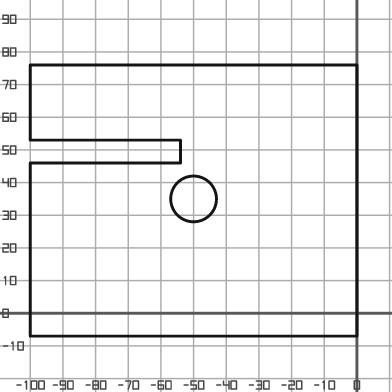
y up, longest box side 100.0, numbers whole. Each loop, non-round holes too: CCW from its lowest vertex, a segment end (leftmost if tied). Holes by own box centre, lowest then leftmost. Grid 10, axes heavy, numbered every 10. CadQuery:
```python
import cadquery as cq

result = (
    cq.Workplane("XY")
    .moveTo(-100.0, -7.0)
    .lineTo(0.0, -7.0)
    .lineTo(0.0, 76.0)
    .lineTo(-100.0, 76.0)
    .lineTo(-100.0, 53.0)
    .lineTo(-54.0, 53.0)
    .lineTo(-54.0, 46.0)
    .lineTo(-100.0, 46.0)
    .close()
    .moveTo(-50.0, 35.0)
    .circle(7.0)
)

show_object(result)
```